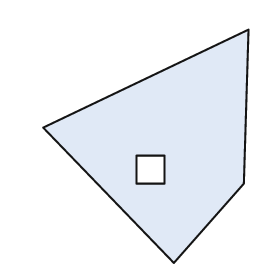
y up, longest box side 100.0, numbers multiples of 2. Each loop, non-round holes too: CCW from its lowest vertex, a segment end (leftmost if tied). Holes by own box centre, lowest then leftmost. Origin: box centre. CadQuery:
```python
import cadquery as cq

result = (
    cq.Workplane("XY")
    .moveTo(12.0, -50.0)
    .lineTo(42.0, -16.0)
    .lineTo(44.0, 50.0)
    .lineTo(-44.0, 8.0)
    .close()
    .moveTo(-4.0, -16.0)
    .lineTo(8.0, -16.0)
    .lineTo(8.0, -4.0)
    .lineTo(-4.0, -4.0)
    .close()
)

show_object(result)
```